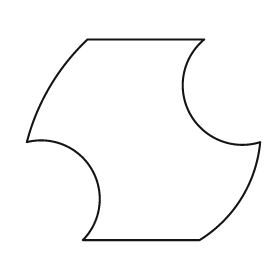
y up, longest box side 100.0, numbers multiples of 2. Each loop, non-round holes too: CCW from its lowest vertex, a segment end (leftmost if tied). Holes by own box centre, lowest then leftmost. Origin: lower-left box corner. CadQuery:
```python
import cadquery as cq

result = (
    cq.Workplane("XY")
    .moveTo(24.0, 0.0)
    .lineTo(74.0, 0.0)
    .threePointArc((92.0, 18.0), (100.0, 42.0))
    .threePointArc((70.0, 54.0), (76.0, 86.0))
    .lineTo(26.0, 86.0)
    .threePointArc((10.0, 66.0), (0.0, 42.0))
    .threePointArc((28.0, 30.0), (24.0, 0.0))
    .close()
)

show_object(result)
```